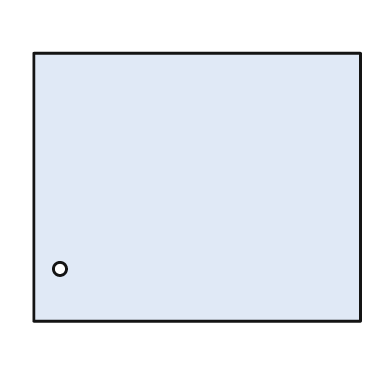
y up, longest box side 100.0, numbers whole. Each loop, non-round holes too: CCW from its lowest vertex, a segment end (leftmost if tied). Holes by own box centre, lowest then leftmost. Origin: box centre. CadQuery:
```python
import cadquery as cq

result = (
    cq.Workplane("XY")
    .moveTo(-50.0, -41.0)
    .lineTo(50.0, -41.0)
    .lineTo(50.0, 41.0)
    .lineTo(-50.0, 41.0)
    .close()
    .moveTo(-42.0, -25.0)
    .circle(2.0)
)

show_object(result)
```